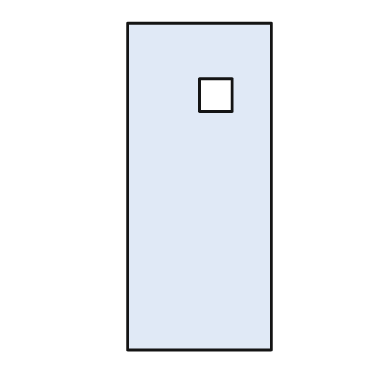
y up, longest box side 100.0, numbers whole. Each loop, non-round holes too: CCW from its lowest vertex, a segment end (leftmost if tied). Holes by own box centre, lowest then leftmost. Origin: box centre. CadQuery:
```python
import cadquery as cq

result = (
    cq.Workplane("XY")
    .moveTo(-22.0, -50.0)
    .lineTo(22.0, -50.0)
    .lineTo(22.0, 50.0)
    .lineTo(-22.0, 50.0)
    .close()
    .moveTo(0.0, 23.0)
    .lineTo(10.0, 23.0)
    .lineTo(10.0, 33.0)
    .lineTo(0.0, 33.0)
    .close()
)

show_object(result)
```